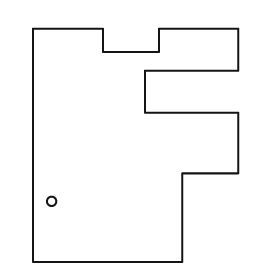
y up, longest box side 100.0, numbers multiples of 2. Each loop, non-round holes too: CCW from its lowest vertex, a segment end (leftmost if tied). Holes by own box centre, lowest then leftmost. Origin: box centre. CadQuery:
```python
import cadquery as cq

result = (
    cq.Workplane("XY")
    .moveTo(-44.0, -50.0)
    .lineTo(20.0, -50.0)
    .lineTo(20.0, -12.0)
    .lineTo(44.0, -12.0)
    .lineTo(44.0, 14.0)
    .lineTo(4.0, 14.0)
    .lineTo(4.0, 32.0)
    .lineTo(44.0, 32.0)
    .lineTo(44.0, 50.0)
    .lineTo(10.0, 50.0)
    .lineTo(10.0, 40.0)
    .lineTo(-14.0, 40.0)
    .lineTo(-14.0, 50.0)
    .lineTo(-44.0, 50.0)
    .close()
    .moveTo(-36.0, -24.0)
    .circle(2.0)
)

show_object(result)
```